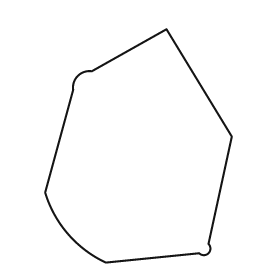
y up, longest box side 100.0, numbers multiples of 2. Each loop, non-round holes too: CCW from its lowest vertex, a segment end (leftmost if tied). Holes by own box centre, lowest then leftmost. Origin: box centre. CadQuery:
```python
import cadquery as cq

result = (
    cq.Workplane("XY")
    .moveTo(-14.0, -50.0)
    .lineTo(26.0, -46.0)
    .threePointArc((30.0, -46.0), (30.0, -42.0))
    .lineTo(40.0, 4.0)
    .lineTo(12.0, 50.0)
    .lineTo(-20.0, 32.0)
    .threePointArc((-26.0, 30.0), (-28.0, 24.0))
    .lineTo(-40.0, -20.0)
    .threePointArc((-30.0, -38.0), (-14.0, -50.0))
    .close()
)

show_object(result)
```